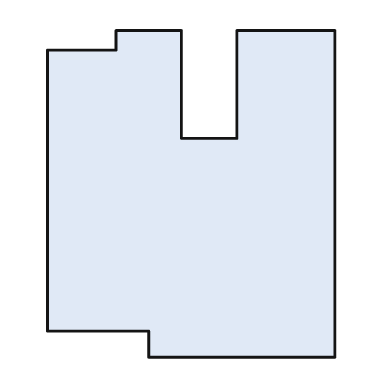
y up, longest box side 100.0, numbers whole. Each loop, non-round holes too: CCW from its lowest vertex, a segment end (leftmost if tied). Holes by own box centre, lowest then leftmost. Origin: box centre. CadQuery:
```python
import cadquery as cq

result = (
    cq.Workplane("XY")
    .moveTo(-13.0, -50.0)
    .lineTo(44.0, -50.0)
    .lineTo(44.0, 50.0)
    .lineTo(14.0, 50.0)
    .lineTo(14.0, 17.0)
    .lineTo(-3.0, 17.0)
    .lineTo(-3.0, 50.0)
    .lineTo(-23.0, 50.0)
    .lineTo(-23.0, 44.0)
    .lineTo(-44.0, 44.0)
    .lineTo(-44.0, -42.0)
    .lineTo(-13.0, -42.0)
    .close()
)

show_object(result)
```